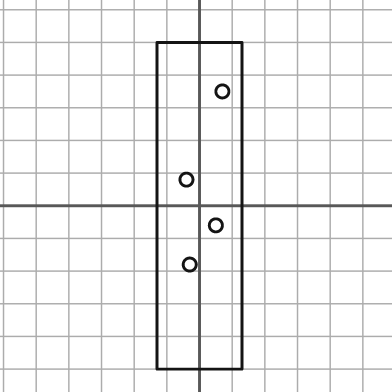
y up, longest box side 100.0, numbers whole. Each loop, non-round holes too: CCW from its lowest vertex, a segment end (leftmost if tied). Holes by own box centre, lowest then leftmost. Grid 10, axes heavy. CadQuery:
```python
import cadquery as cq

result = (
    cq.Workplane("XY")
    .moveTo(-13.0, -50.0)
    .lineTo(13.0, -50.0)
    .lineTo(13.0, 50.0)
    .lineTo(-13.0, 50.0)
    .close()
    .moveTo(-3.0, -18.0)
    .circle(2.0)
    .moveTo(5.0, -6.0)
    .circle(2.0)
    .moveTo(-4.0, 8.0)
    .circle(2.0)
    .moveTo(7.0, 35.0)
    .circle(2.0)
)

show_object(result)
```